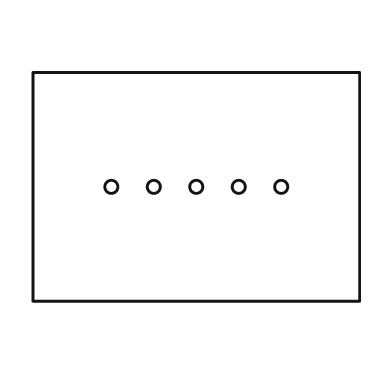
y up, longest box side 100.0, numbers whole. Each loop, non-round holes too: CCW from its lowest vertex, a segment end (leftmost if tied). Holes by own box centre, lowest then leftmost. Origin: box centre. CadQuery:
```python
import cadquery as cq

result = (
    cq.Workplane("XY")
    .moveTo(-50.0, -35.0)
    .lineTo(50.0, -35.0)
    .lineTo(50.0, 35.0)
    .lineTo(-50.0, 35.0)
    .close()
    .moveTo(-26.0, 0.0)
    .circle(2.0)
    .moveTo(-13.0, 0.0)
    .circle(2.0)
    .moveTo(0.0, 0.0)
    .circle(2.0)
    .moveTo(13.0, 0.0)
    .circle(2.0)
    .moveTo(26.0, 0.0)
    .circle(2.0)
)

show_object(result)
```